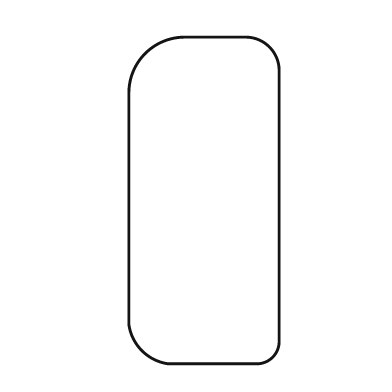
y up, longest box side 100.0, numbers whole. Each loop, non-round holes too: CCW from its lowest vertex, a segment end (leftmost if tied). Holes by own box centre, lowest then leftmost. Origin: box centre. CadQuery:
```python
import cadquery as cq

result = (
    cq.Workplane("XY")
    .moveTo(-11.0, -50.0)
    .lineTo(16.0, -50.0)
    .threePointArc((21.0, -48.0), (23.0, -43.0))
    .lineTo(23.0, 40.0)
    .threePointArc((20.0, 47.0), (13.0, 50.0))
    .lineTo(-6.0, 50.0)
    .threePointArc((-18.0, 45.0), (-23.0, 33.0))
    .lineTo(-23.0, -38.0)
    .threePointArc((-19.0, -46.0), (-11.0, -50.0))
    .close()
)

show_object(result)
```